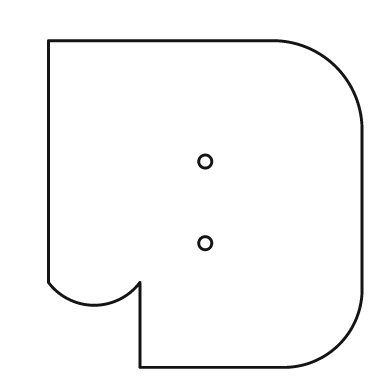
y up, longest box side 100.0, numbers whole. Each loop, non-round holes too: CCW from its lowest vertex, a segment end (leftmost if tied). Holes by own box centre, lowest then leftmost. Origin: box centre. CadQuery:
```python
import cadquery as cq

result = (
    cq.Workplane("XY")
    .moveTo(-20.0, -50.0)
    .lineTo(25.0, -50.0)
    .threePointArc((41.0, -43.0), (48.0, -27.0))
    .lineTo(48.0, 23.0)
    .threePointArc((40.0, 42.0), (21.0, 50.0))
    .lineTo(-48.0, 50.0)
    .lineTo(-48.0, -24.0)
    .threePointArc((-34.0, -31.0), (-20.0, -24.0))
    .close()
    .moveTo(0.0, -12.0)
    .circle(2.0)
    .moveTo(0.0, 13.0)
    .circle(2.0)
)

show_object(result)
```